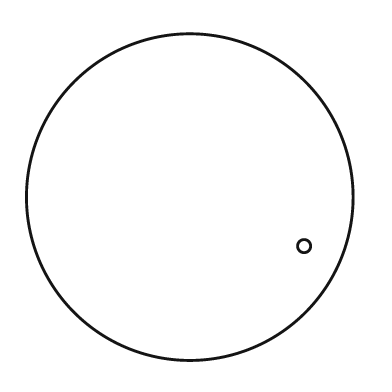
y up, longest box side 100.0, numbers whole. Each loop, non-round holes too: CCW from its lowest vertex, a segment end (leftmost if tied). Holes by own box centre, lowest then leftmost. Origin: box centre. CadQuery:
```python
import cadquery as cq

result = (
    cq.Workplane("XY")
    .moveTo(0.0, 0.0)
    .circle(50.0)
    .moveTo(35.0, -15.0)
    .circle(2.0)
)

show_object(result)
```